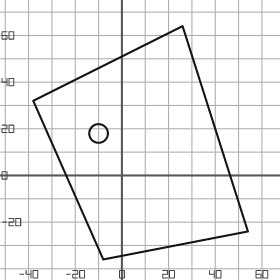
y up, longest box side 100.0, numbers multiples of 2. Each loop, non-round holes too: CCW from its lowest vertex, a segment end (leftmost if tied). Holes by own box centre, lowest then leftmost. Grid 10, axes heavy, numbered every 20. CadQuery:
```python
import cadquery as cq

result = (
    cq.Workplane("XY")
    .moveTo(-8.0, -36.0)
    .lineTo(54.0, -24.0)
    .lineTo(26.0, 64.0)
    .lineTo(-38.0, 32.0)
    .close()
    .moveTo(-10.0, 18.0)
    .circle(4.0)
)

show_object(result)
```